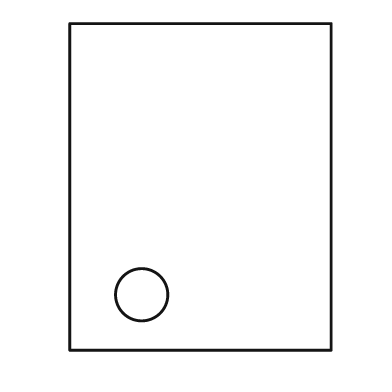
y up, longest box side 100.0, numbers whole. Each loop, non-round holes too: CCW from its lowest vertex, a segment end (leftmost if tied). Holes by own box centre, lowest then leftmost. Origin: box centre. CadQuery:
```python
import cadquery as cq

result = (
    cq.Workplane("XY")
    .moveTo(-40.0, -50.0)
    .lineTo(40.0, -50.0)
    .lineTo(40.0, 50.0)
    .lineTo(-40.0, 50.0)
    .close()
    .moveTo(-18.0, -33.0)
    .circle(8.0)
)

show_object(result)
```